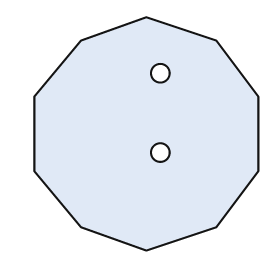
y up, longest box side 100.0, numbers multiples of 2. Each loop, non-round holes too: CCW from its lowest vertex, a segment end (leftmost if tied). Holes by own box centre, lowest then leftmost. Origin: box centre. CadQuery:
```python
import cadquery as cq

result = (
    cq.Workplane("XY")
    .moveTo(0.0, -50.0)
    .lineTo(30.0, -40.0)
    .lineTo(48.0, -16.0)
    .lineTo(48.0, 16.0)
    .lineTo(30.0, 40.0)
    .lineTo(0.0, 50.0)
    .lineTo(-28.0, 40.0)
    .lineTo(-48.0, 16.0)
    .lineTo(-48.0, -16.0)
    .lineTo(-28.0, -40.0)
    .close()
    .moveTo(6.0, -8.0)
    .circle(4.0)
    .moveTo(6.0, 26.0)
    .circle(4.0)
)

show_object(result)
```